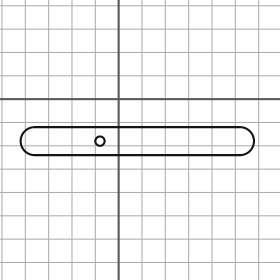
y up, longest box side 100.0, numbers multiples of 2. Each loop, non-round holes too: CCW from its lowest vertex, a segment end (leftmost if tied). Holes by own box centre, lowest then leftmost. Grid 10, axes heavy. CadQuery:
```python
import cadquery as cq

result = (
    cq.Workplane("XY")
    .moveTo(-36.0, -24.0)
    .lineTo(52.0, -24.0)
    .threePointArc((58.0, -18.0), (52.0, -12.0))
    .lineTo(-36.0, -12.0)
    .threePointArc((-42.0, -18.0), (-36.0, -24.0))
    .close()
    .moveTo(-8.0, -18.0)
    .circle(2.0)
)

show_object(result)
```